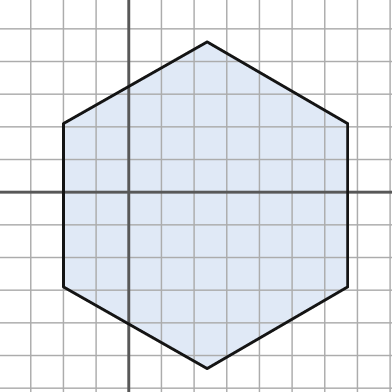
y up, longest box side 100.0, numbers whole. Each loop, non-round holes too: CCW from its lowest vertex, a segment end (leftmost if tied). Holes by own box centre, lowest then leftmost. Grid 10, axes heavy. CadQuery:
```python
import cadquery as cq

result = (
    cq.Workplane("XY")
    .moveTo(24.0, -54.0)
    .lineTo(67.0, -29.0)
    .lineTo(67.0, 21.0)
    .lineTo(24.0, 46.0)
    .lineTo(-20.0, 21.0)
    .lineTo(-20.0, -29.0)
    .close()
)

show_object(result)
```